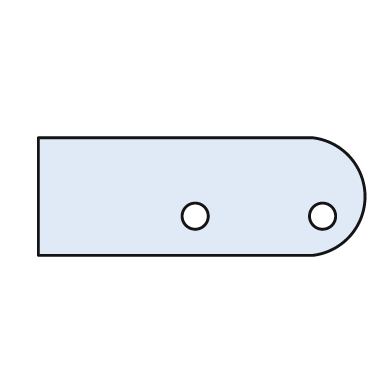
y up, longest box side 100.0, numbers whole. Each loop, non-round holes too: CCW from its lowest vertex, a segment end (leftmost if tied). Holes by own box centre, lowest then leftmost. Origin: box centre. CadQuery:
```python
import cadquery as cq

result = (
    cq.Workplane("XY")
    .moveTo(-50.0, -18.0)
    .lineTo(34.0, -18.0)
    .threePointArc((50.0, 0.0), (34.0, 18.0))
    .lineTo(-50.0, 18.0)
    .close()
    .moveTo(-2.0, -6.0)
    .circle(4.0)
    .moveTo(37.0, -6.0)
    .circle(4.0)
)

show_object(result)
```